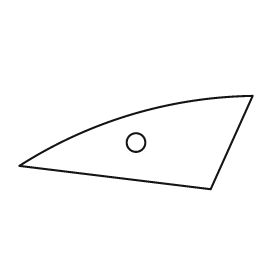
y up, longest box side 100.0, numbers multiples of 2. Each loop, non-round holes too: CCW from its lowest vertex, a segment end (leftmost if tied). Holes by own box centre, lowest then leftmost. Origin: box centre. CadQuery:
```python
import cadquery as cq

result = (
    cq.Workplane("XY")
    .moveTo(32.0, -20.0)
    .lineTo(50.0, 20.0)
    .threePointArc((-2.0, 12.0), (-50.0, -10.0))
    .close()
    .moveTo(0.0, 0.0)
    .circle(4.0)
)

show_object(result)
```